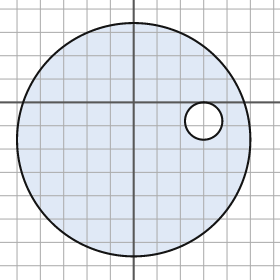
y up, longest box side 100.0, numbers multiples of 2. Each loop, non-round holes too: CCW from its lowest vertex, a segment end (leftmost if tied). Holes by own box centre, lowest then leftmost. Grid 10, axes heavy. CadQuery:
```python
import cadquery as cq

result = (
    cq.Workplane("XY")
    .moveTo(0.0, -16.0)
    .circle(50.0)
    .moveTo(30.0, -8.0)
    .circle(8.0)
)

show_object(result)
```